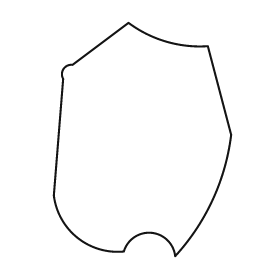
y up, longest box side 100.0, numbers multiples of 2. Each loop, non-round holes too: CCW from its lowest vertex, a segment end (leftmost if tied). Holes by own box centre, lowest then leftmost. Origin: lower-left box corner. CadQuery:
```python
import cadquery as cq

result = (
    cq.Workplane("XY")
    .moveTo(52.0, 0.0)
    .threePointArc((68.0, 24.0), (76.0, 52.0))
    .lineTo(66.0, 90.0)
    .threePointArc((48.0, 92.0), (32.0, 100.0))
    .lineTo(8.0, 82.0)
    .threePointArc((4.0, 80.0), (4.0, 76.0))
    .lineTo(0.0, 26.0)
    .threePointArc((10.0, 8.0), (30.0, 2.0))
    .threePointArc((42.0, 10.0), (52.0, 0.0))
    .close()
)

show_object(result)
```